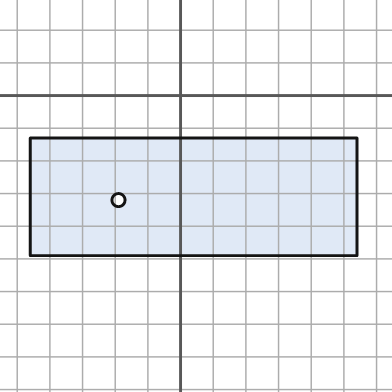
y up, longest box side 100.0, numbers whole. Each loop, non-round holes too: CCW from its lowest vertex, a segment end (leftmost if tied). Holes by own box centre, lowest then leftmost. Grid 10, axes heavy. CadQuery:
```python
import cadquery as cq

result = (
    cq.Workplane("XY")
    .moveTo(-46.0, -49.0)
    .lineTo(54.0, -49.0)
    .lineTo(54.0, -13.0)
    .lineTo(-46.0, -13.0)
    .close()
    .moveTo(-19.0, -32.0)
    .circle(2.0)
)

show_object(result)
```